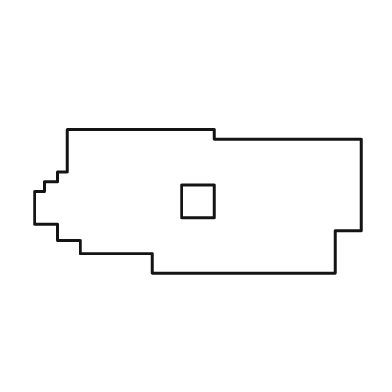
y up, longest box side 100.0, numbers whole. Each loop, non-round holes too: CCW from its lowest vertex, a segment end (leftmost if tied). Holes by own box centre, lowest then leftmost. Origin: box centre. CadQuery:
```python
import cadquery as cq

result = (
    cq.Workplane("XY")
    .moveTo(-14.0, -22.0)
    .lineTo(42.0, -22.0)
    .lineTo(42.0, -9.0)
    .lineTo(50.0, -9.0)
    .lineTo(50.0, 19.0)
    .lineTo(5.0, 19.0)
    .lineTo(5.0, 22.0)
    .lineTo(-40.0, 22.0)
    .lineTo(-40.0, 9.0)
    .lineTo(-43.0, 9.0)
    .lineTo(-43.0, 6.0)
    .lineTo(-47.0, 6.0)
    .lineTo(-47.0, 3.0)
    .lineTo(-50.0, 3.0)
    .lineTo(-50.0, -7.0)
    .lineTo(-43.0, -7.0)
    .lineTo(-43.0, -12.0)
    .lineTo(-36.0, -12.0)
    .lineTo(-36.0, -16.0)
    .lineTo(-14.0, -16.0)
    .close()
    .moveTo(-5.0, -5.0)
    .lineTo(5.0, -5.0)
    .lineTo(5.0, 5.0)
    .lineTo(-5.0, 5.0)
    .close()
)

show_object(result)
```